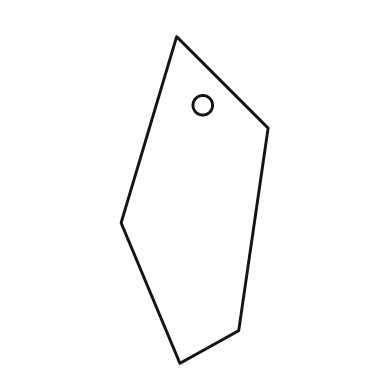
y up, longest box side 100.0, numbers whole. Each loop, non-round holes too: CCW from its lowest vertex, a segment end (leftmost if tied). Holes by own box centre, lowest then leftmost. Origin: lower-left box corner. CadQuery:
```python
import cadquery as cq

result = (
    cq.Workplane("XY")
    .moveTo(18.0, 0.0)
    .lineTo(36.0, 10.0)
    .lineTo(45.0, 72.0)
    .lineTo(17.0, 100.0)
    .lineTo(0.0, 43.0)
    .close()
    .moveTo(25.0, 79.0)
    .circle(3.0)
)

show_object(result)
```